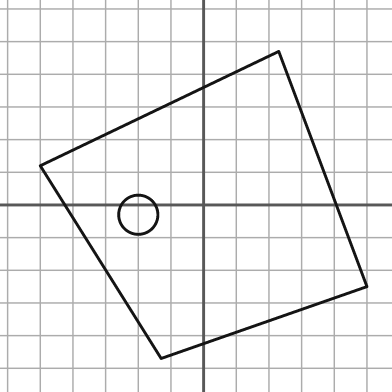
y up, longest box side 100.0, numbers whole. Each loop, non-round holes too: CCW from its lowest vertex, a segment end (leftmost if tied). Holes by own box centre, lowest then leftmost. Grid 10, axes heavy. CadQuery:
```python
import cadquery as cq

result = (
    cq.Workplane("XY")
    .moveTo(-13.0, -47.0)
    .lineTo(50.0, -25.0)
    .lineTo(23.0, 47.0)
    .lineTo(-50.0, 12.0)
    .close()
    .moveTo(-20.0, -3.0)
    .circle(6.0)
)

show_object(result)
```